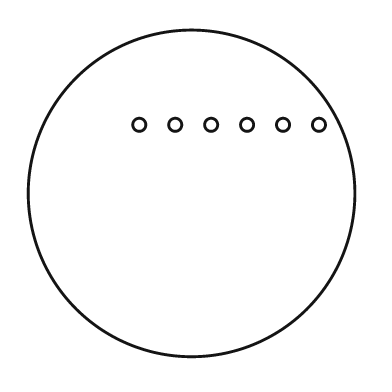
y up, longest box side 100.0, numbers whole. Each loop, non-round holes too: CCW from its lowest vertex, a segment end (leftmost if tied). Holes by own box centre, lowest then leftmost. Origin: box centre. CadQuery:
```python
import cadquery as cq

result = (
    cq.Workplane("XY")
    .moveTo(0.0, 0.0)
    .circle(50.0)
    .moveTo(-16.0, 21.0)
    .circle(2.0)
    .moveTo(-5.0, 21.0)
    .circle(2.0)
    .moveTo(6.0, 21.0)
    .circle(2.0)
    .moveTo(17.0, 21.0)
    .circle(2.0)
    .moveTo(28.0, 21.0)
    .circle(2.0)
    .moveTo(39.0, 21.0)
    .circle(2.0)
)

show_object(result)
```